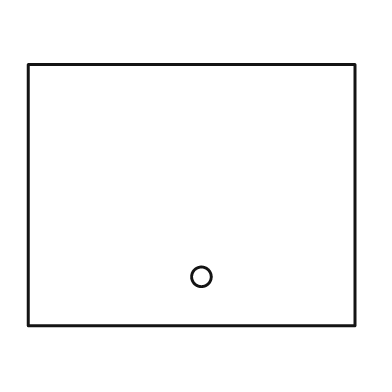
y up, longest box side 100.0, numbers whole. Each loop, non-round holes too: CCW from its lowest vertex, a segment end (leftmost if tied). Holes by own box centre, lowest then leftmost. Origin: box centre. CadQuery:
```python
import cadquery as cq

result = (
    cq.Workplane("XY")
    .moveTo(-50.0, -40.0)
    .lineTo(50.0, -40.0)
    .lineTo(50.0, 40.0)
    .lineTo(-50.0, 40.0)
    .close()
    .moveTo(3.0, -25.0)
    .circle(3.0)
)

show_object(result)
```